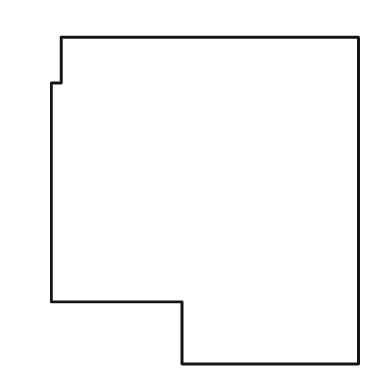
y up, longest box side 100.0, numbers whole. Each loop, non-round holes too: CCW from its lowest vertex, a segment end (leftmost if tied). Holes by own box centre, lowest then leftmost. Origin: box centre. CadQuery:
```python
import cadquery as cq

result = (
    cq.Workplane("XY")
    .moveTo(-7.0, -50.0)
    .lineTo(47.0, -50.0)
    .lineTo(47.0, 50.0)
    .lineTo(-44.0, 50.0)
    .lineTo(-44.0, 36.0)
    .lineTo(-47.0, 36.0)
    .lineTo(-47.0, -31.0)
    .lineTo(-7.0, -31.0)
    .close()
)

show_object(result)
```